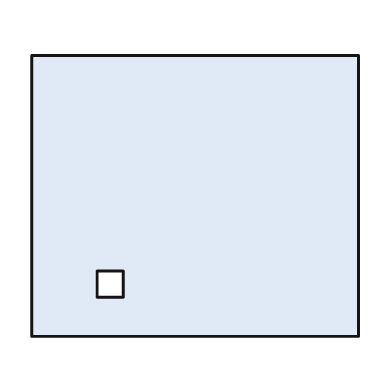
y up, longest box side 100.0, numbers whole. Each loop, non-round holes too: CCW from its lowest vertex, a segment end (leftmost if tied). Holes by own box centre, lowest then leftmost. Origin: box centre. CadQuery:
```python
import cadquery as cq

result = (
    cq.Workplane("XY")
    .moveTo(-50.0, -43.0)
    .lineTo(50.0, -43.0)
    .lineTo(50.0, 43.0)
    .lineTo(-50.0, 43.0)
    .close()
    .moveTo(-30.0, -31.0)
    .lineTo(-22.0, -31.0)
    .lineTo(-22.0, -23.0)
    .lineTo(-30.0, -23.0)
    .close()
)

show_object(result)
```